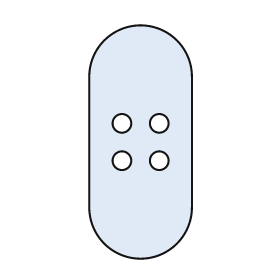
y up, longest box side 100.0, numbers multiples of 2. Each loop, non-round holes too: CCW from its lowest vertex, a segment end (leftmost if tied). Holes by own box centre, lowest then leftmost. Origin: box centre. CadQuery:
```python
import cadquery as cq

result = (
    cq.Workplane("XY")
    .moveTo(-22.0, -28.0)
    .threePointArc((0.0, -50.0), (22.0, -28.0))
    .lineTo(22.0, 28.0)
    .threePointArc((0.0, 50.0), (-22.0, 28.0))
    .close()
    .moveTo(-8.0, -8.0)
    .circle(4.0)
    .moveTo(8.0, -8.0)
    .circle(4.0)
    .moveTo(-8.0, 8.0)
    .circle(4.0)
    .moveTo(8.0, 8.0)
    .circle(4.0)
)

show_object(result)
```